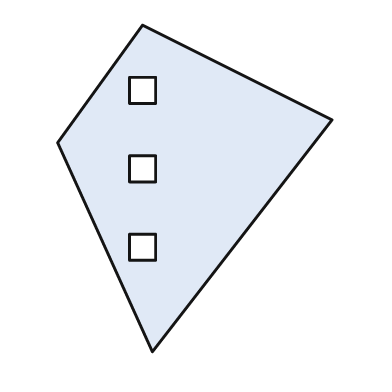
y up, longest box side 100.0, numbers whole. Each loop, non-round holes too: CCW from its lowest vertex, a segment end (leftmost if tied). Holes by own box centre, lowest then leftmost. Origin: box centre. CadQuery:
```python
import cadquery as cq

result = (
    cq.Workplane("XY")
    .moveTo(-13.0, -50.0)
    .lineTo(42.0, 21.0)
    .lineTo(-16.0, 50.0)
    .lineTo(-42.0, 14.0)
    .close()
    .moveTo(-20.0, -22.0)
    .lineTo(-12.0, -22.0)
    .lineTo(-12.0, -14.0)
    .lineTo(-20.0, -14.0)
    .close()
    .moveTo(-20.0, 2.0)
    .lineTo(-12.0, 2.0)
    .lineTo(-12.0, 10.0)
    .lineTo(-20.0, 10.0)
    .close()
    .moveTo(-20.0, 26.0)
    .lineTo(-12.0, 26.0)
    .lineTo(-12.0, 34.0)
    .lineTo(-20.0, 34.0)
    .close()
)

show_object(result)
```